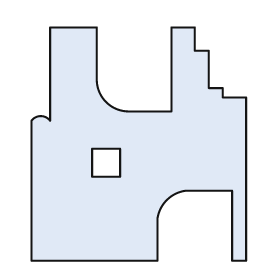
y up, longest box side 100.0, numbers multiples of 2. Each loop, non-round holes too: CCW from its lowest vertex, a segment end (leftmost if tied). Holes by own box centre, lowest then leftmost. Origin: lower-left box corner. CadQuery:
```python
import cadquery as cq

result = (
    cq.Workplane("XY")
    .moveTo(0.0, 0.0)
    .lineTo(54.0, 0.0)
    .lineTo(54.0, 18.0)
    .threePointArc((58.0, 26.0), (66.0, 30.0))
    .lineTo(86.0, 30.0)
    .lineTo(86.0, 0.0)
    .lineTo(92.0, 0.0)
    .lineTo(92.0, 70.0)
    .lineTo(82.0, 70.0)
    .lineTo(82.0, 74.0)
    .lineTo(76.0, 74.0)
    .lineTo(76.0, 90.0)
    .lineTo(70.0, 90.0)
    .lineTo(70.0, 100.0)
    .lineTo(60.0, 100.0)
    .lineTo(60.0, 64.0)
    .lineTo(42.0, 64.0)
    .threePointArc((32.0, 68.0), (28.0, 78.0))
    .lineTo(28.0, 100.0)
    .lineTo(8.0, 100.0)
    .lineTo(8.0, 60.0)
    .threePointArc((4.0, 62.0), (0.0, 60.0))
    .close()
    .moveTo(26.0, 36.0)
    .lineTo(38.0, 36.0)
    .lineTo(38.0, 48.0)
    .lineTo(26.0, 48.0)
    .close()
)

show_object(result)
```